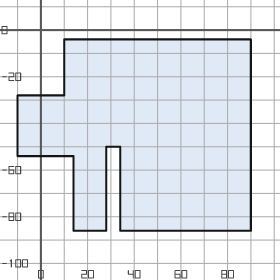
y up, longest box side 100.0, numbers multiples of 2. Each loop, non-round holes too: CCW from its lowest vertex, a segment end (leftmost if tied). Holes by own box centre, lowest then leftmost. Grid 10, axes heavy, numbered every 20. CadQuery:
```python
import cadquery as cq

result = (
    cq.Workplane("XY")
    .moveTo(14.0, -86.0)
    .lineTo(28.0, -86.0)
    .lineTo(28.0, -50.0)
    .lineTo(34.0, -50.0)
    .lineTo(34.0, -86.0)
    .lineTo(90.0, -86.0)
    .lineTo(90.0, -4.0)
    .lineTo(10.0, -4.0)
    .lineTo(10.0, -28.0)
    .lineTo(-10.0, -28.0)
    .lineTo(-10.0, -54.0)
    .lineTo(14.0, -54.0)
    .close()
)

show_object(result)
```